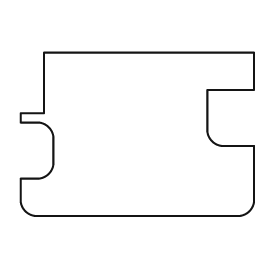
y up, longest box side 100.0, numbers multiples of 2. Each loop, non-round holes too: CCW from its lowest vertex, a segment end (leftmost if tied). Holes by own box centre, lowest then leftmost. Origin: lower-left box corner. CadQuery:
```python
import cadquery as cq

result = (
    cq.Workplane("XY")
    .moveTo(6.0, 0.0)
    .lineTo(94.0, 0.0)
    .threePointArc((98.0, 2.0), (100.0, 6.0))
    .lineTo(100.0, 30.0)
    .lineTo(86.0, 30.0)
    .threePointArc((82.0, 32.0), (80.0, 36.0))
    .lineTo(80.0, 54.0)
    .lineTo(100.0, 54.0)
    .lineTo(100.0, 70.0)
    .lineTo(10.0, 70.0)
    .lineTo(10.0, 44.0)
    .lineTo(0.0, 44.0)
    .lineTo(0.0, 40.0)
    .lineTo(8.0, 40.0)
    .threePointArc((12.0, 38.0), (14.0, 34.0))
    .lineTo(14.0, 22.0)
    .threePointArc((12.0, 18.0), (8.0, 16.0))
    .lineTo(0.0, 16.0)
    .lineTo(0.0, 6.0)
    .threePointArc((2.0, 2.0), (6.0, 0.0))
    .close()
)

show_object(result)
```